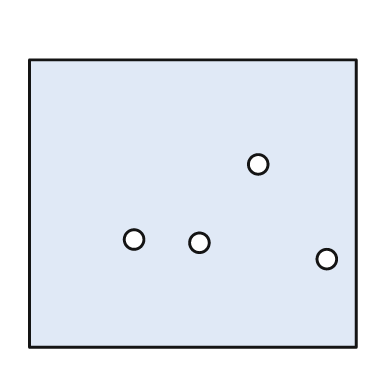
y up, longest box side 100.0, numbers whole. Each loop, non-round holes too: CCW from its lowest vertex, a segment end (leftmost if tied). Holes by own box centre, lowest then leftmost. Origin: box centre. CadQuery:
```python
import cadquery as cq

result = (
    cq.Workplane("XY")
    .moveTo(-50.0, -44.0)
    .lineTo(50.0, -44.0)
    .lineTo(50.0, 44.0)
    .lineTo(-50.0, 44.0)
    .close()
    .moveTo(41.0, -17.0)
    .circle(3.0)
    .moveTo(2.0, -12.0)
    .circle(3.0)
    .moveTo(-18.0, -11.0)
    .circle(3.0)
    .moveTo(20.0, 12.0)
    .circle(3.0)
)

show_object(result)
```